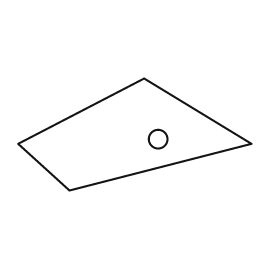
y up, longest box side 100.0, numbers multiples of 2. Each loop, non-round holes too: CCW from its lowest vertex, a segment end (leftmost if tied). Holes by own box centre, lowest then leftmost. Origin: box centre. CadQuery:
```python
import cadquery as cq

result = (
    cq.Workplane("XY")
    .moveTo(-28.0, -24.0)
    .lineTo(50.0, -4.0)
    .lineTo(4.0, 24.0)
    .lineTo(-50.0, -4.0)
    .close()
    .moveTo(10.0, -2.0)
    .circle(4.0)
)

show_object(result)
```